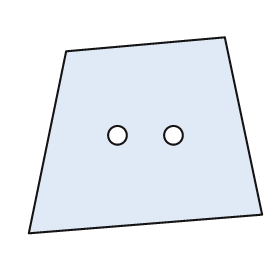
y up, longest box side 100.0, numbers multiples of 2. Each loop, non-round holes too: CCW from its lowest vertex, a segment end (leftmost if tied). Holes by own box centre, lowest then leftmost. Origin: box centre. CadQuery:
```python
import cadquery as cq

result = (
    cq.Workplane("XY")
    .moveTo(-50.0, -42.0)
    .lineTo(50.0, -34.0)
    .lineTo(34.0, 42.0)
    .lineTo(-34.0, 36.0)
    .close()
    .moveTo(-12.0, 0.0)
    .circle(4.0)
    .moveTo(12.0, 0.0)
    .circle(4.0)
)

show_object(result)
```